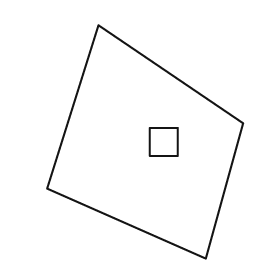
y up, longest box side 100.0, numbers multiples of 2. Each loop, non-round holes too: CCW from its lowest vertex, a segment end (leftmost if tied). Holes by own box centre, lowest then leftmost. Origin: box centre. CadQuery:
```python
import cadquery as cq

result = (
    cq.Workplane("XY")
    .moveTo(26.0, -50.0)
    .lineTo(42.0, 8.0)
    .lineTo(-20.0, 50.0)
    .lineTo(-42.0, -20.0)
    .close()
    .moveTo(2.0, -6.0)
    .lineTo(14.0, -6.0)
    .lineTo(14.0, 6.0)
    .lineTo(2.0, 6.0)
    .close()
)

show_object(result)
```